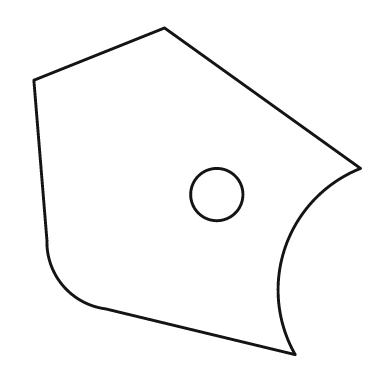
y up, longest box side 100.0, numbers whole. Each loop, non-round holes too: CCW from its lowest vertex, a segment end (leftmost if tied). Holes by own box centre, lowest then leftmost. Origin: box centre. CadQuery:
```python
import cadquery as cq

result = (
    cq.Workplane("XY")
    .moveTo(30.0, -50.0)
    .threePointArc((27.0, -17.0), (50.0, 7.0))
    .lineTo(-10.0, 50.0)
    .lineTo(-50.0, 34.0)
    .lineTo(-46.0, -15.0)
    .threePointArc((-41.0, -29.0), (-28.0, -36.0))
    .close()
    .moveTo(6.0, -1.0)
    .circle(8.0)
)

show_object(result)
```